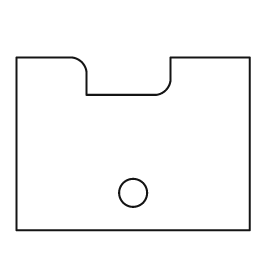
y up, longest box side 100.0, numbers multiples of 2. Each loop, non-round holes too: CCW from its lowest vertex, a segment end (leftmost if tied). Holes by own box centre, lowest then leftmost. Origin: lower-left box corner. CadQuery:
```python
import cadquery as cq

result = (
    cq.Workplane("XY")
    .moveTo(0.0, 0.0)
    .lineTo(100.0, 0.0)
    .lineTo(100.0, 74.0)
    .lineTo(66.0, 74.0)
    .lineTo(66.0, 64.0)
    .threePointArc((64.0, 60.0), (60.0, 58.0))
    .lineTo(30.0, 58.0)
    .lineTo(30.0, 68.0)
    .threePointArc((28.0, 72.0), (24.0, 74.0))
    .lineTo(0.0, 74.0)
    .close()
    .moveTo(50.0, 16.0)
    .circle(6.0)
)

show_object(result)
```